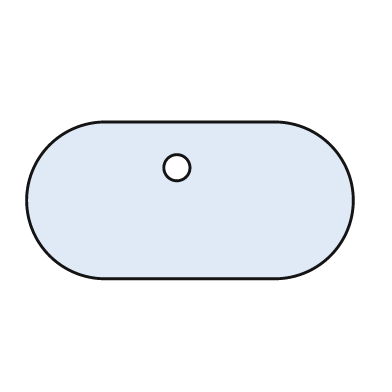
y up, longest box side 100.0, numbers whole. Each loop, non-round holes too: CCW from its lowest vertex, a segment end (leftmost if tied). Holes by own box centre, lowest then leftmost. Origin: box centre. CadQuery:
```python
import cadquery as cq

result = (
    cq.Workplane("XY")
    .moveTo(-26.0, -24.0)
    .lineTo(26.0, -24.0)
    .threePointArc((50.0, 0.0), (26.0, 24.0))
    .lineTo(-26.0, 24.0)
    .threePointArc((-50.0, 0.0), (-26.0, -24.0))
    .close()
    .moveTo(-4.0, 10.0)
    .circle(4.0)
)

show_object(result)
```